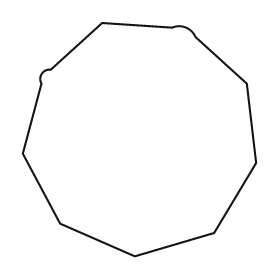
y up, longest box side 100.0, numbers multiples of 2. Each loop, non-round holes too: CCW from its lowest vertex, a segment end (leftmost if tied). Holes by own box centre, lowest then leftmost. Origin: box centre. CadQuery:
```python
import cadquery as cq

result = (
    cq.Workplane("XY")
    .moveTo(-2.0, -50.0)
    .lineTo(32.0, -40.0)
    .lineTo(50.0, -10.0)
    .lineTo(46.0, 24.0)
    .lineTo(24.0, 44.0)
    .threePointArc((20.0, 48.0), (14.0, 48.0))
    .lineTo(-16.0, 50.0)
    .lineTo(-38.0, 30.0)
    .threePointArc((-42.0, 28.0), (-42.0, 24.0))
    .lineTo(-50.0, -6.0)
    .lineTo(-34.0, -36.0)
    .close()
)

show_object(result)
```